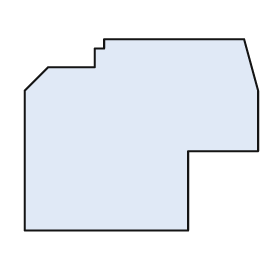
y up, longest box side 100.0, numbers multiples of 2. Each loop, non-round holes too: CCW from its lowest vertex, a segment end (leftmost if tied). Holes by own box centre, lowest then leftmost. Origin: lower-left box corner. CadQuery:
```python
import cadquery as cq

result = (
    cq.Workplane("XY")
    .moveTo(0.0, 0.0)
    .lineTo(70.0, 0.0)
    .lineTo(70.0, 34.0)
    .lineTo(100.0, 34.0)
    .lineTo(100.0, 60.0)
    .lineTo(94.0, 82.0)
    .lineTo(34.0, 82.0)
    .lineTo(34.0, 78.0)
    .lineTo(30.0, 78.0)
    .lineTo(30.0, 70.0)
    .lineTo(10.0, 70.0)
    .lineTo(0.0, 60.0)
    .close()
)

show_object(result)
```